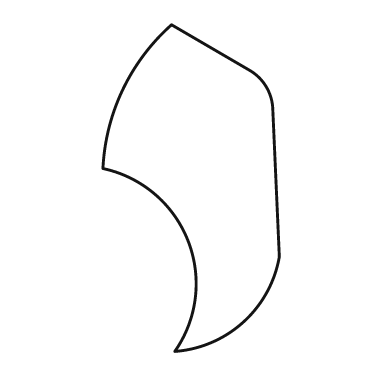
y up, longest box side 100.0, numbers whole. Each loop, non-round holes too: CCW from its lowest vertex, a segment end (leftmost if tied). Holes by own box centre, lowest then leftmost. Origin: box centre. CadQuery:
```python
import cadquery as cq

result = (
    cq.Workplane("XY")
    .moveTo(-5.0, -50.0)
    .threePointArc((16.0, -41.0), (27.0, -21.0))
    .lineTo(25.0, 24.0)
    .threePointArc((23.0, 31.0), (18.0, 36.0))
    .lineTo(-6.0, 50.0)
    .threePointArc((-21.0, 30.0), (-27.0, 6.0))
    .threePointArc((-1.0, -16.0), (-5.0, -50.0))
    .close()
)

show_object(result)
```